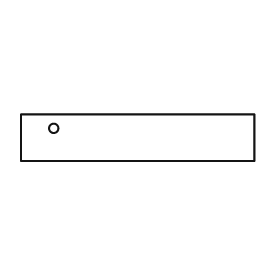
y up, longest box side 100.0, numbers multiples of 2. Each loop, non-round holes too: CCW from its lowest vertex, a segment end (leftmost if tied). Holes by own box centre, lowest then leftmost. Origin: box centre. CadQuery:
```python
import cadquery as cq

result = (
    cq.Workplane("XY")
    .moveTo(-50.0, -10.0)
    .lineTo(50.0, -10.0)
    .lineTo(50.0, 10.0)
    .lineTo(-50.0, 10.0)
    .close()
    .moveTo(-36.0, 4.0)
    .circle(2.0)
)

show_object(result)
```